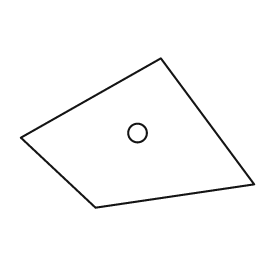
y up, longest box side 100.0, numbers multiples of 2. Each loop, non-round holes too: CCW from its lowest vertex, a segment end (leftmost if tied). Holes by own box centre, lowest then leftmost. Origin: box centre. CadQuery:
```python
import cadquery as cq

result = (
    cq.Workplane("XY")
    .moveTo(-18.0, -32.0)
    .lineTo(50.0, -22.0)
    .lineTo(10.0, 32.0)
    .lineTo(-50.0, -2.0)
    .close()
    .moveTo(0.0, 0.0)
    .circle(4.0)
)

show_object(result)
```